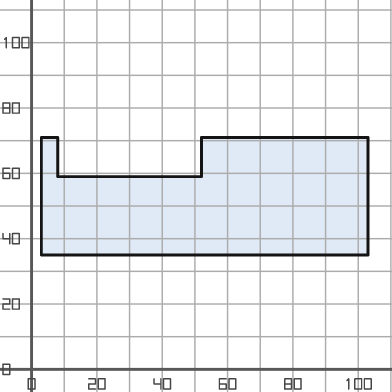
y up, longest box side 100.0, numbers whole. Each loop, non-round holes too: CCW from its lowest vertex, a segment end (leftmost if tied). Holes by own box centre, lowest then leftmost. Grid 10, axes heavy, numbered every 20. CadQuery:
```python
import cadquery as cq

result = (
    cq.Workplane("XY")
    .moveTo(3.0, 35.0)
    .lineTo(103.0, 35.0)
    .lineTo(103.0, 71.0)
    .lineTo(52.0, 71.0)
    .lineTo(52.0, 59.0)
    .lineTo(8.0, 59.0)
    .lineTo(8.0, 71.0)
    .lineTo(3.0, 71.0)
    .close()
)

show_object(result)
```